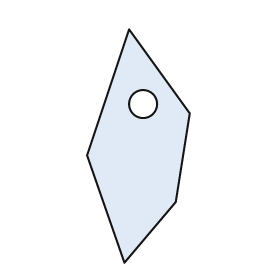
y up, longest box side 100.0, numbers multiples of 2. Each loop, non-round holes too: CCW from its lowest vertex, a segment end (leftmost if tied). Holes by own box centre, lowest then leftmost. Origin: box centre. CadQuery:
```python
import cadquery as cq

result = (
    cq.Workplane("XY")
    .moveTo(-6.0, -50.0)
    .lineTo(16.0, -24.0)
    .lineTo(22.0, 14.0)
    .lineTo(-4.0, 50.0)
    .lineTo(-22.0, -4.0)
    .close()
    .moveTo(2.0, 18.0)
    .circle(6.0)
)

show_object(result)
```